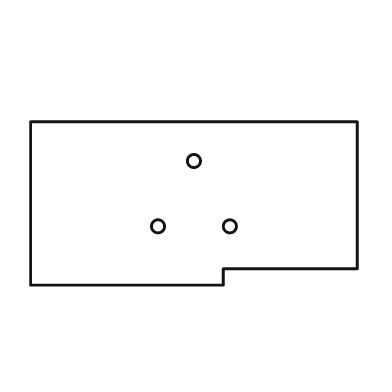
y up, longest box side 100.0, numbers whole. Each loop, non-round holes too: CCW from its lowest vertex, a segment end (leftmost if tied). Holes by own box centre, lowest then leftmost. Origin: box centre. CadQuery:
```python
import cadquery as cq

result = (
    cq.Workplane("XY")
    .moveTo(-50.0, -25.0)
    .lineTo(9.0, -25.0)
    .lineTo(9.0, -20.0)
    .lineTo(50.0, -20.0)
    .lineTo(50.0, 25.0)
    .lineTo(-50.0, 25.0)
    .close()
    .moveTo(-11.0, -7.0)
    .circle(2.0)
    .moveTo(11.0, -7.0)
    .circle(2.0)
    .moveTo(0.0, 13.0)
    .circle(2.0)
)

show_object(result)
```